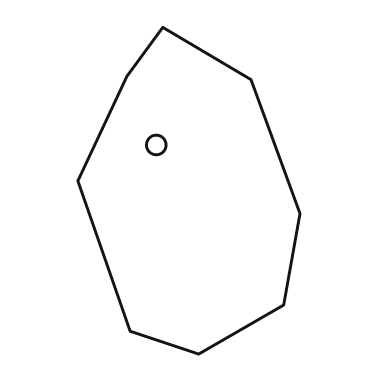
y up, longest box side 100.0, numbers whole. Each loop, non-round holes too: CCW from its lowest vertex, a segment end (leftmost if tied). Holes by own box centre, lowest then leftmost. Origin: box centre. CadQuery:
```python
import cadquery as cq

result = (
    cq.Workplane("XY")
    .moveTo(3.0, -50.0)
    .lineTo(29.0, -35.0)
    .lineTo(34.0, -7.0)
    .lineTo(19.0, 34.0)
    .lineTo(-8.0, 50.0)
    .lineTo(-19.0, 35.0)
    .lineTo(-34.0, 3.0)
    .lineTo(-18.0, -43.0)
    .close()
    .moveTo(-10.0, 14.0)
    .circle(3.0)
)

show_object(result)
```